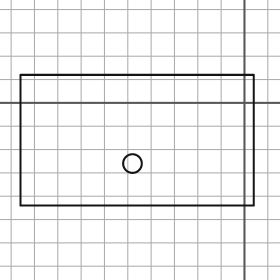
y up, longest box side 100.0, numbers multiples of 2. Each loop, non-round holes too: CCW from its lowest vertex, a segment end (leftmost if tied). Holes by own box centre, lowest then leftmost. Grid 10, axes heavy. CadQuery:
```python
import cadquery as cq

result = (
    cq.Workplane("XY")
    .moveTo(-96.0, -44.0)
    .lineTo(4.0, -44.0)
    .lineTo(4.0, 12.0)
    .lineTo(-96.0, 12.0)
    .close()
    .moveTo(-48.0, -26.0)
    .circle(4.0)
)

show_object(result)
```